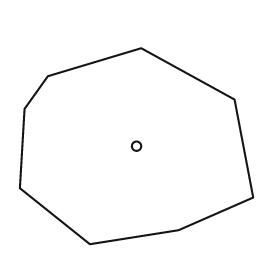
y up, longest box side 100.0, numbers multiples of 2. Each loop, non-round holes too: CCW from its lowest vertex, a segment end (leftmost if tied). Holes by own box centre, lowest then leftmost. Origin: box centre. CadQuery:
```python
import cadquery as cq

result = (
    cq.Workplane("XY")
    .moveTo(-20.0, -42.0)
    .lineTo(18.0, -36.0)
    .lineTo(50.0, -22.0)
    .lineTo(42.0, 20.0)
    .lineTo(2.0, 42.0)
    .lineTo(-38.0, 30.0)
    .lineTo(-48.0, 16.0)
    .lineTo(-50.0, -18.0)
    .close()
    .moveTo(0.0, 0.0)
    .circle(2.0)
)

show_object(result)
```